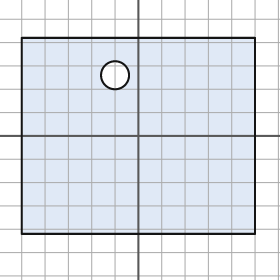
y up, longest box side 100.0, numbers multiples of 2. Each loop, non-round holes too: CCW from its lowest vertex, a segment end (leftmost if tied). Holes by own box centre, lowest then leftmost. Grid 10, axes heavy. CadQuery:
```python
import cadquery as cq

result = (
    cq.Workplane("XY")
    .moveTo(-50.0, -42.0)
    .lineTo(50.0, -42.0)
    .lineTo(50.0, 42.0)
    .lineTo(-50.0, 42.0)
    .close()
    .moveTo(-10.0, 26.0)
    .circle(6.0)
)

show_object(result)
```